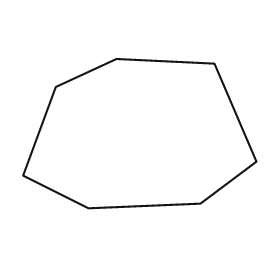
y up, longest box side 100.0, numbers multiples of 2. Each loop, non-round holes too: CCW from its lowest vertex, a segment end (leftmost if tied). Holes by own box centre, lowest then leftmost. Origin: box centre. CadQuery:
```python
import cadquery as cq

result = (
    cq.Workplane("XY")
    .moveTo(-22.0, -32.0)
    .lineTo(26.0, -30.0)
    .lineTo(50.0, -12.0)
    .lineTo(32.0, 30.0)
    .lineTo(-10.0, 32.0)
    .lineTo(-36.0, 20.0)
    .lineTo(-50.0, -18.0)
    .close()
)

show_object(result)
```